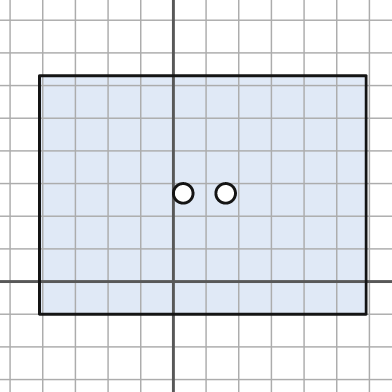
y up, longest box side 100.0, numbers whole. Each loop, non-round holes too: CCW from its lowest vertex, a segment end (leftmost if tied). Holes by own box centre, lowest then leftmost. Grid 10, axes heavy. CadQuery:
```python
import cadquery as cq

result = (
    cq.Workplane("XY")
    .moveTo(-41.0, -10.0)
    .lineTo(59.0, -10.0)
    .lineTo(59.0, 63.0)
    .lineTo(-41.0, 63.0)
    .close()
    .moveTo(3.0, 27.0)
    .circle(3.0)
    .moveTo(16.0, 27.0)
    .circle(3.0)
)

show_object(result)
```